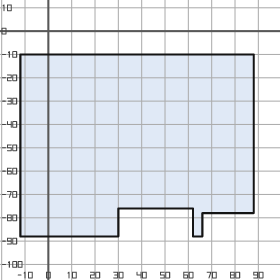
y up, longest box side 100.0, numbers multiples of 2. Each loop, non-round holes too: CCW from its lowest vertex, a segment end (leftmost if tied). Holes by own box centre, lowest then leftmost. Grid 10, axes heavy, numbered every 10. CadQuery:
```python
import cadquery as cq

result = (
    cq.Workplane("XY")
    .moveTo(-12.0, -88.0)
    .lineTo(30.0, -88.0)
    .lineTo(30.0, -76.0)
    .lineTo(62.0, -76.0)
    .lineTo(62.0, -88.0)
    .lineTo(66.0, -88.0)
    .lineTo(66.0, -78.0)
    .lineTo(88.0, -78.0)
    .lineTo(88.0, -10.0)
    .lineTo(-12.0, -10.0)
    .close()
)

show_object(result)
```